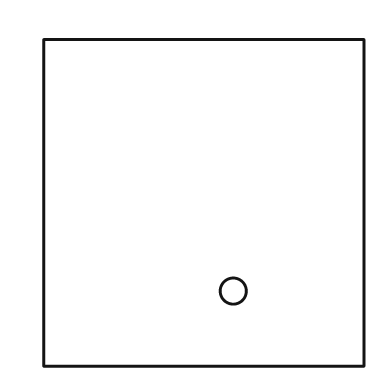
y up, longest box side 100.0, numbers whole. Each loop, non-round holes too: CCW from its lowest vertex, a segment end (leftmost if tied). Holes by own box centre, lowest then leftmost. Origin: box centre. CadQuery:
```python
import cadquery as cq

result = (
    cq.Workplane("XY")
    .moveTo(-49.0, -50.0)
    .lineTo(49.0, -50.0)
    .lineTo(49.0, 50.0)
    .lineTo(-49.0, 50.0)
    .close()
    .moveTo(9.0, -27.0)
    .circle(4.0)
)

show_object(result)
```